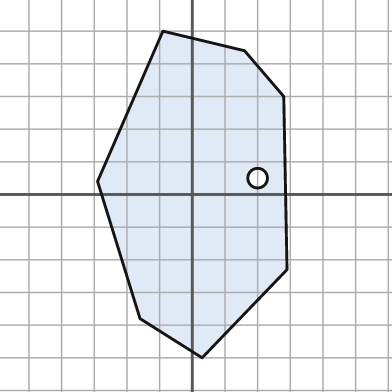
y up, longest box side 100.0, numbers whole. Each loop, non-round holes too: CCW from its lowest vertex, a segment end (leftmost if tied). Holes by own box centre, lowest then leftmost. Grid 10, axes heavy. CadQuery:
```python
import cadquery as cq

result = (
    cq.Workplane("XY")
    .moveTo(3.0, -50.0)
    .lineTo(29.0, -23.0)
    .lineTo(28.0, 30.0)
    .lineTo(16.0, 44.0)
    .lineTo(-9.0, 50.0)
    .lineTo(-29.0, 4.0)
    .lineTo(-16.0, -38.0)
    .close()
    .moveTo(20.0, 5.0)
    .circle(3.0)
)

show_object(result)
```